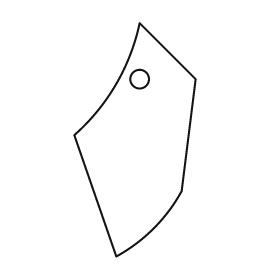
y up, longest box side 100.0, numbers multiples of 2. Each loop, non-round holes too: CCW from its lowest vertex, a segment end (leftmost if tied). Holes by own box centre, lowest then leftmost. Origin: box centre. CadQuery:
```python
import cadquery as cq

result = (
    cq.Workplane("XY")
    .moveTo(-8.0, -50.0)
    .threePointArc((8.0, -38.0), (20.0, -22.0))
    .lineTo(26.0, 26.0)
    .lineTo(2.0, 50.0)
    .threePointArc((-8.0, 24.0), (-26.0, 2.0))
    .close()
    .moveTo(2.0, 26.0)
    .circle(4.0)
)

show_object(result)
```